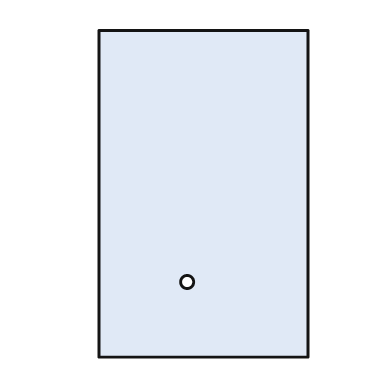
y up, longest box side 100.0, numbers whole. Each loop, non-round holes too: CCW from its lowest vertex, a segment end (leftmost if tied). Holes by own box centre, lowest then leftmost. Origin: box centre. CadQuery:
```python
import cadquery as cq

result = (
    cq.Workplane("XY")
    .moveTo(-32.0, -50.0)
    .lineTo(32.0, -50.0)
    .lineTo(32.0, 50.0)
    .lineTo(-32.0, 50.0)
    .close()
    .moveTo(-5.0, -27.0)
    .circle(2.0)
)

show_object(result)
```